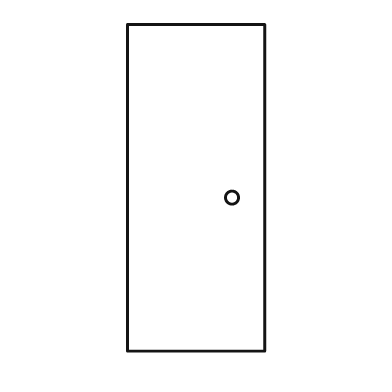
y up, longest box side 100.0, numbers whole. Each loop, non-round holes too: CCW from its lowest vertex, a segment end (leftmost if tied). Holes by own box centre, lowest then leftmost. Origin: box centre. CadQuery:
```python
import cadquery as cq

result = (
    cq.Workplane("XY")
    .moveTo(-21.0, -50.0)
    .lineTo(21.0, -50.0)
    .lineTo(21.0, 50.0)
    .lineTo(-21.0, 50.0)
    .close()
    .moveTo(11.0, -3.0)
    .circle(2.0)
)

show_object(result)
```